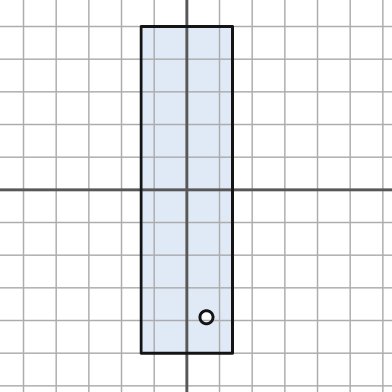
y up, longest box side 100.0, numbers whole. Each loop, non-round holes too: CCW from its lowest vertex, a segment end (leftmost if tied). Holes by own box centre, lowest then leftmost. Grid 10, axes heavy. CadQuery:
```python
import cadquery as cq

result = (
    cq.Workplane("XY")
    .moveTo(-14.0, -50.0)
    .lineTo(14.0, -50.0)
    .lineTo(14.0, 50.0)
    .lineTo(-14.0, 50.0)
    .close()
    .moveTo(6.0, -39.0)
    .circle(2.0)
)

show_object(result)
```